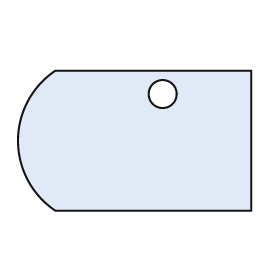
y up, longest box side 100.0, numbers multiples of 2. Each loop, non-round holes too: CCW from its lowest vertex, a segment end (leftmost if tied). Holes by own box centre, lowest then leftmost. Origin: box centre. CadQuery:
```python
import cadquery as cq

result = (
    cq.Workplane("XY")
    .moveTo(-34.0, -30.0)
    .lineTo(50.0, -30.0)
    .lineTo(50.0, 30.0)
    .lineTo(-34.0, 30.0)
    .threePointArc((-50.0, 0.0), (-34.0, -30.0))
    .close()
    .moveTo(12.0, 20.0)
    .circle(6.0)
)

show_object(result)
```